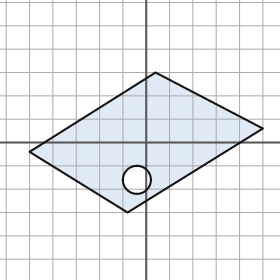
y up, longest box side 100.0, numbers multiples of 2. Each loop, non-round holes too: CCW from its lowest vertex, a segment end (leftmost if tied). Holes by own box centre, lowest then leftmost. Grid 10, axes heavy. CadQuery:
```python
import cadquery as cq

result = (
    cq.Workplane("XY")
    .moveTo(-8.0, -30.0)
    .lineTo(50.0, 6.0)
    .lineTo(4.0, 30.0)
    .lineTo(-50.0, -4.0)
    .close()
    .moveTo(-4.0, -16.0)
    .circle(6.0)
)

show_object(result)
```